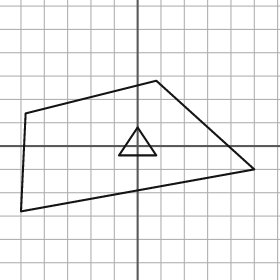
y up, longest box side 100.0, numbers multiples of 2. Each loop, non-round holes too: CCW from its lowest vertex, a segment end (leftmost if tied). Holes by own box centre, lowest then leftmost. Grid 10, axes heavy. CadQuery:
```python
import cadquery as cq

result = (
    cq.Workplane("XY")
    .moveTo(-50.0, -28.0)
    .lineTo(50.0, -10.0)
    .lineTo(8.0, 28.0)
    .lineTo(-48.0, 14.0)
    .close()
    .moveTo(-8.0, -4.0)
    .lineTo(8.0, -4.0)
    .lineTo(0.0, 8.0)
    .close()
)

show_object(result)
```